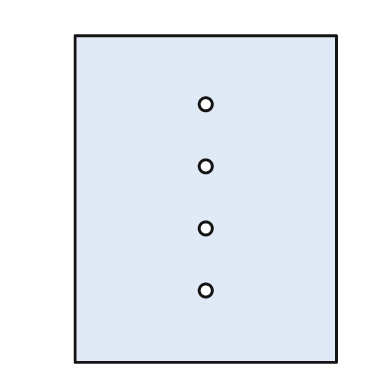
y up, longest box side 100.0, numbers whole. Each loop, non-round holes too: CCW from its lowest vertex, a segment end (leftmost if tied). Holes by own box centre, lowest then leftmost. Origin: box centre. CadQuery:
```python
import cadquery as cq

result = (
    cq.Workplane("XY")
    .moveTo(-40.0, -50.0)
    .lineTo(40.0, -50.0)
    .lineTo(40.0, 50.0)
    .lineTo(-40.0, 50.0)
    .close()
    .moveTo(0.0, -28.0)
    .circle(2.0)
    .moveTo(0.0, -9.0)
    .circle(2.0)
    .moveTo(0.0, 10.0)
    .circle(2.0)
    .moveTo(0.0, 29.0)
    .circle(2.0)
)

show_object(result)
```